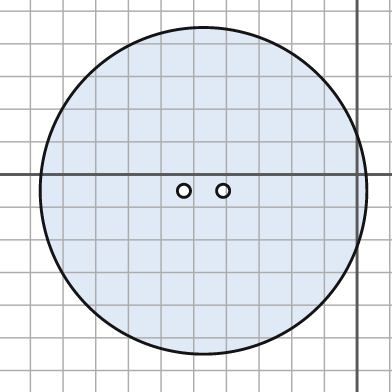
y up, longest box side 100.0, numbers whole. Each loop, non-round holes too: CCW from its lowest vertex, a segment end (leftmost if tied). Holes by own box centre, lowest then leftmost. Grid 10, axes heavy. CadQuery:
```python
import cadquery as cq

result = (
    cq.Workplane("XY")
    .moveTo(-47.0, -5.0)
    .circle(50.0)
    .moveTo(-53.0, -5.0)
    .circle(2.0)
    .moveTo(-41.0, -5.0)
    .circle(2.0)
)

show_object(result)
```